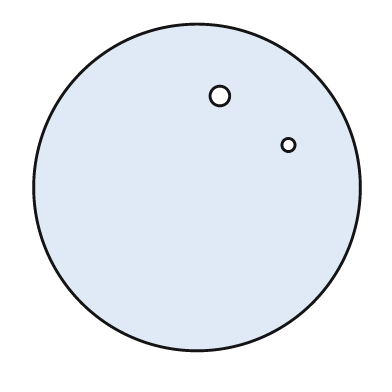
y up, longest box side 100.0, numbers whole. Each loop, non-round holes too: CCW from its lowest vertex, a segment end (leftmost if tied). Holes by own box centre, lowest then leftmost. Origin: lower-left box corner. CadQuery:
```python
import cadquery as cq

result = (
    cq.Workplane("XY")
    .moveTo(50.0, 50.0)
    .circle(50.0)
    .moveTo(78.0, 63.0)
    .circle(2.0)
    .moveTo(57.0, 78.0)
    .circle(3.0)
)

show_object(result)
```